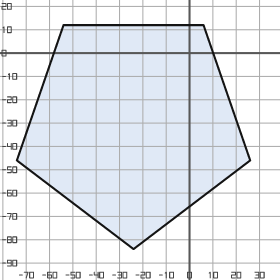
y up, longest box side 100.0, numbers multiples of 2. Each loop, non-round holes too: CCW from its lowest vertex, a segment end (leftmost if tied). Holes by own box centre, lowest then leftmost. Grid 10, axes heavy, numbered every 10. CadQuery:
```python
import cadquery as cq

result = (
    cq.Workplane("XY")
    .moveTo(-24.0, -84.0)
    .lineTo(26.0, -46.0)
    .lineTo(6.0, 12.0)
    .lineTo(-54.0, 12.0)
    .lineTo(-74.0, -46.0)
    .close()
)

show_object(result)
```